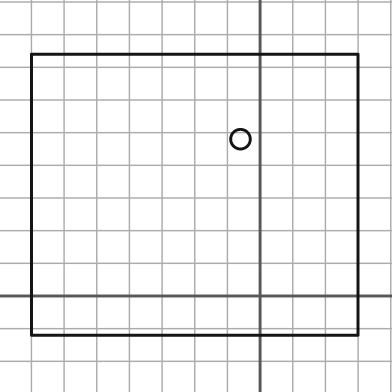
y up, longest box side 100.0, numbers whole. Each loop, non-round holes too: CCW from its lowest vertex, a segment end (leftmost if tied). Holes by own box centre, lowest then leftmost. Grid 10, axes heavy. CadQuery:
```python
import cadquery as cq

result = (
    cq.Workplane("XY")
    .moveTo(-70.0, -12.0)
    .lineTo(30.0, -12.0)
    .lineTo(30.0, 74.0)
    .lineTo(-70.0, 74.0)
    .close()
    .moveTo(-6.0, 48.0)
    .circle(3.0)
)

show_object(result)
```